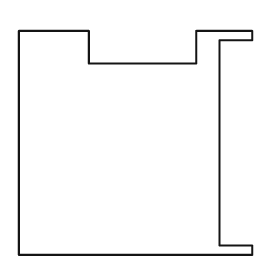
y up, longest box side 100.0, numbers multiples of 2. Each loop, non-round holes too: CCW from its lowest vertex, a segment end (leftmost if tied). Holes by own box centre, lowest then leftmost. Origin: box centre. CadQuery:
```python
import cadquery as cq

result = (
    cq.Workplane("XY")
    .moveTo(-50.0, -48.0)
    .lineTo(50.0, -48.0)
    .lineTo(50.0, -44.0)
    .lineTo(36.0, -44.0)
    .lineTo(36.0, 44.0)
    .lineTo(50.0, 44.0)
    .lineTo(50.0, 48.0)
    .lineTo(26.0, 48.0)
    .lineTo(26.0, 34.0)
    .lineTo(-20.0, 34.0)
    .lineTo(-20.0, 48.0)
    .lineTo(-50.0, 48.0)
    .close()
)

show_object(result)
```